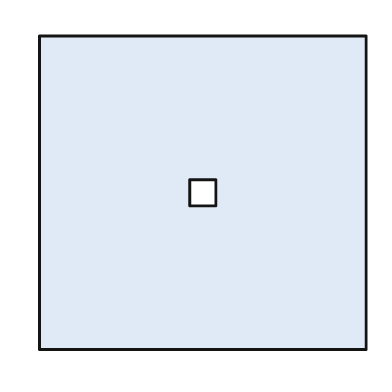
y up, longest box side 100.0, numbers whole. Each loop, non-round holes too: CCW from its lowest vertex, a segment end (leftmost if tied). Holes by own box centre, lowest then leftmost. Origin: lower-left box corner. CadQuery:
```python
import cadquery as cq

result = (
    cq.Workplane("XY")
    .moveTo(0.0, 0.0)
    .lineTo(100.0, 0.0)
    .lineTo(100.0, 96.0)
    .lineTo(0.0, 96.0)
    .close()
    .moveTo(46.0, 44.0)
    .lineTo(54.0, 44.0)
    .lineTo(54.0, 52.0)
    .lineTo(46.0, 52.0)
    .close()
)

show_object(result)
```